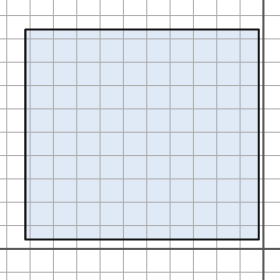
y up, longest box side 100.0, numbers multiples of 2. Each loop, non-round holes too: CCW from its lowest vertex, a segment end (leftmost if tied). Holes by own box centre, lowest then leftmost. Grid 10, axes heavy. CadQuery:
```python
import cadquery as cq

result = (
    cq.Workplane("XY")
    .moveTo(-102.0, 4.0)
    .lineTo(-2.0, 4.0)
    .lineTo(-2.0, 94.0)
    .lineTo(-102.0, 94.0)
    .close()
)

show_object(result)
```